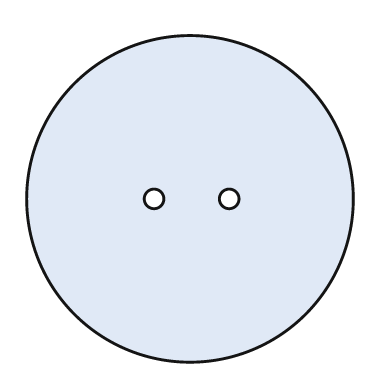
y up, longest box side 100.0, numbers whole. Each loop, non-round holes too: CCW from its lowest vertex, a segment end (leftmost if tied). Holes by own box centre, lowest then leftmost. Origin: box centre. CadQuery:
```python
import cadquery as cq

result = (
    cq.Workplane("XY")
    .moveTo(0.0, 0.0)
    .circle(50.0)
    .moveTo(-11.0, 0.0)
    .circle(3.0)
    .moveTo(12.0, 0.0)
    .circle(3.0)
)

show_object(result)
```